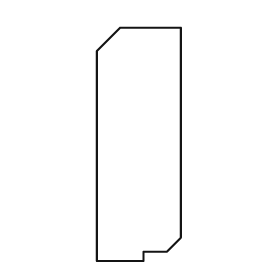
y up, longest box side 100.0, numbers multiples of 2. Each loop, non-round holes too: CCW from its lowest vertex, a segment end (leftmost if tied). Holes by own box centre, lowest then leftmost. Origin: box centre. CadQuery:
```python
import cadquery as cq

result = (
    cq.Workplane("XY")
    .moveTo(-18.0, -50.0)
    .lineTo(2.0, -50.0)
    .lineTo(2.0, -46.0)
    .lineTo(12.0, -46.0)
    .lineTo(18.0, -40.0)
    .lineTo(18.0, 50.0)
    .lineTo(-8.0, 50.0)
    .lineTo(-18.0, 40.0)
    .close()
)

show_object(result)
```